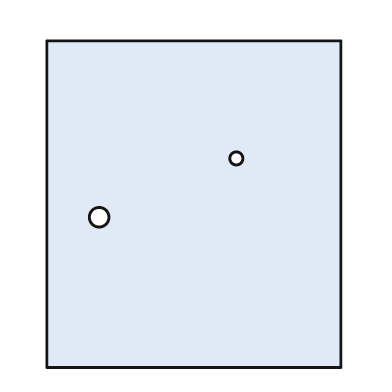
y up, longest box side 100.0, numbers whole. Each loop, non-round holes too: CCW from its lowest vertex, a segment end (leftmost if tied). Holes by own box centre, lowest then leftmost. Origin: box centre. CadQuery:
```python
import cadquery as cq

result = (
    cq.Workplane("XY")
    .moveTo(-45.0, -50.0)
    .lineTo(45.0, -50.0)
    .lineTo(45.0, 50.0)
    .lineTo(-45.0, 50.0)
    .close()
    .moveTo(-29.0, -4.0)
    .circle(3.0)
    .moveTo(13.0, 14.0)
    .circle(2.0)
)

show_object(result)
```